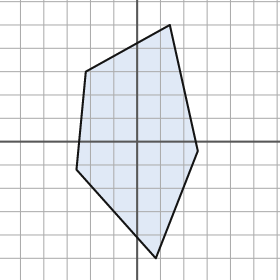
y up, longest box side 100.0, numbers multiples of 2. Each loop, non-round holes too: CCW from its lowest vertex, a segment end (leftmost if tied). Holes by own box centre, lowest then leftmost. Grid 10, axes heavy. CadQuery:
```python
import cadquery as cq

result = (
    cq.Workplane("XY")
    .moveTo(8.0, -50.0)
    .lineTo(26.0, -4.0)
    .lineTo(14.0, 50.0)
    .lineTo(-22.0, 30.0)
    .lineTo(-26.0, -12.0)
    .close()
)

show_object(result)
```